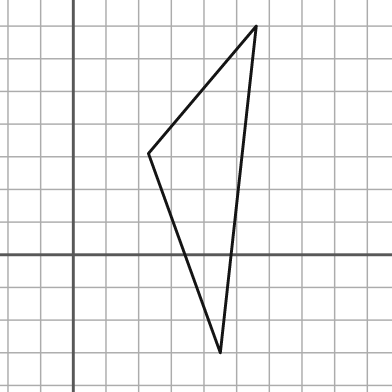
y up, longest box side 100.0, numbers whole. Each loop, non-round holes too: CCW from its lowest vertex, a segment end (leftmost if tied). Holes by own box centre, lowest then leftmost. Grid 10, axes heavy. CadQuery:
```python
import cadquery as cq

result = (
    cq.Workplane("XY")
    .moveTo(45.0, -30.0)
    .lineTo(56.0, 70.0)
    .lineTo(23.0, 31.0)
    .close()
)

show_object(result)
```